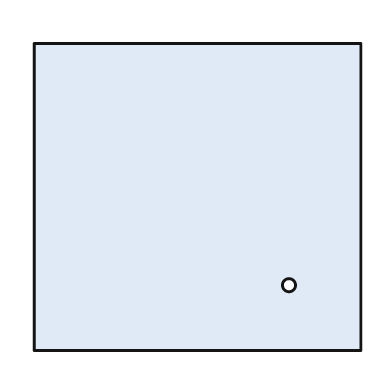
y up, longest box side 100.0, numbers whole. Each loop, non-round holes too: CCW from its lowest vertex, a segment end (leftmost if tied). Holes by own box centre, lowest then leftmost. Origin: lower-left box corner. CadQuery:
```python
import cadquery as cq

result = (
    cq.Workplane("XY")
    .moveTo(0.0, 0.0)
    .lineTo(100.0, 0.0)
    .lineTo(100.0, 94.0)
    .lineTo(0.0, 94.0)
    .close()
    .moveTo(78.0, 20.0)
    .circle(2.0)
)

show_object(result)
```